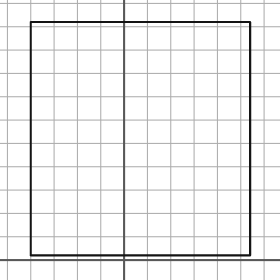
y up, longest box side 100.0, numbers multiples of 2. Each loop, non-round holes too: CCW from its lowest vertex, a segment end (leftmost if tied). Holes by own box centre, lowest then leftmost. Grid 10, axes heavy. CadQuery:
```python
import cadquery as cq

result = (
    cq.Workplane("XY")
    .moveTo(-40.0, 2.0)
    .lineTo(54.0, 2.0)
    .lineTo(54.0, 102.0)
    .lineTo(-40.0, 102.0)
    .close()
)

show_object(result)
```